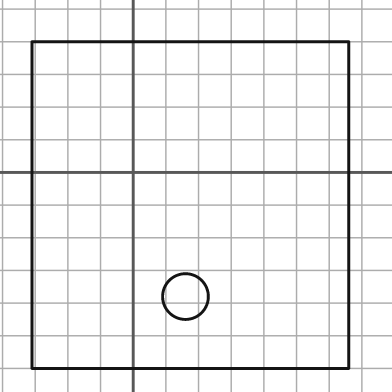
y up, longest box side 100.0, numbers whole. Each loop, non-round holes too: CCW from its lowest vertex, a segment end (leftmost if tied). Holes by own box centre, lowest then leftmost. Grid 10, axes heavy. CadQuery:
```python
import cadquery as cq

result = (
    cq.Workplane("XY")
    .moveTo(-31.0, -60.0)
    .lineTo(66.0, -60.0)
    .lineTo(66.0, 40.0)
    .lineTo(-31.0, 40.0)
    .close()
    .moveTo(16.0, -38.0)
    .circle(7.0)
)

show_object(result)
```